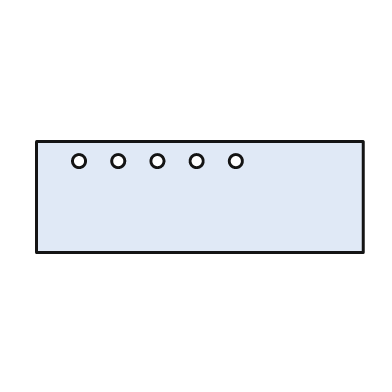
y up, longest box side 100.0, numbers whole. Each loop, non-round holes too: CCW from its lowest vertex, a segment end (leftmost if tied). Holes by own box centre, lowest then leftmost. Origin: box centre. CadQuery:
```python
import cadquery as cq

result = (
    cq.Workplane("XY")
    .moveTo(-50.0, -17.0)
    .lineTo(50.0, -17.0)
    .lineTo(50.0, 17.0)
    .lineTo(-50.0, 17.0)
    .close()
    .moveTo(-37.0, 11.0)
    .circle(2.0)
    .moveTo(-25.0, 11.0)
    .circle(2.0)
    .moveTo(-13.0, 11.0)
    .circle(2.0)
    .moveTo(-1.0, 11.0)
    .circle(2.0)
    .moveTo(11.0, 11.0)
    .circle(2.0)
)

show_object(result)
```